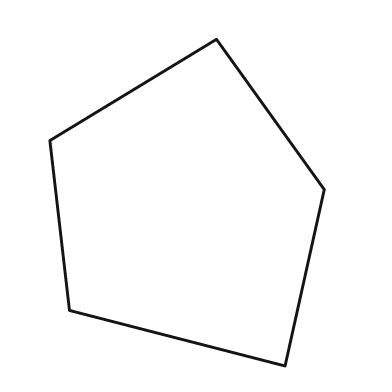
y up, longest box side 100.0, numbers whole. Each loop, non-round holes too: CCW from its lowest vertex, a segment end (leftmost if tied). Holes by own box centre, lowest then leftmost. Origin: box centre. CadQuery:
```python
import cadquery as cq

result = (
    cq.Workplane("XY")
    .moveTo(30.0, -50.0)
    .lineTo(42.0, 4.0)
    .lineTo(9.0, 50.0)
    .lineTo(-42.0, 19.0)
    .lineTo(-36.0, -33.0)
    .close()
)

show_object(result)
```